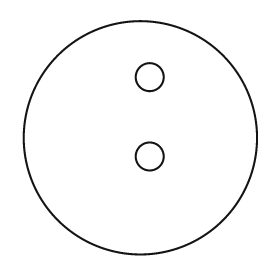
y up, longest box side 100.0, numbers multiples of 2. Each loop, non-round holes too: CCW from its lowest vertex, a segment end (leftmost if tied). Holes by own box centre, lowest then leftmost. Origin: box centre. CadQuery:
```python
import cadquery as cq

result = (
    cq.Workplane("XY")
    .moveTo(0.0, 0.0)
    .circle(50.0)
    .moveTo(4.0, -8.0)
    .circle(6.0)
    .moveTo(4.0, 26.0)
    .circle(6.0)
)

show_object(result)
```